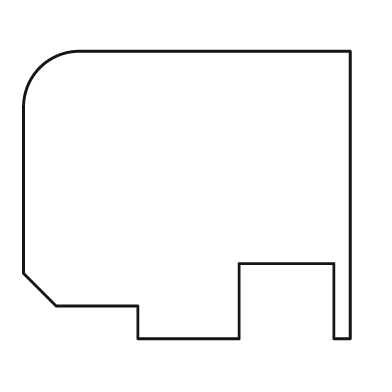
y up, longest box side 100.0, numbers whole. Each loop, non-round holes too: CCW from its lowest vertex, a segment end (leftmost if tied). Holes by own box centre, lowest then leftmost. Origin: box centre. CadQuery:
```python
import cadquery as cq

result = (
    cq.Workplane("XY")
    .moveTo(-15.0, -44.0)
    .lineTo(16.0, -44.0)
    .lineTo(16.0, -21.0)
    .lineTo(45.0, -21.0)
    .lineTo(45.0, -44.0)
    .lineTo(50.0, -44.0)
    .lineTo(50.0, 44.0)
    .lineTo(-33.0, 44.0)
    .threePointArc((-45.0, 39.0), (-50.0, 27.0))
    .lineTo(-50.0, -24.0)
    .lineTo(-40.0, -34.0)
    .lineTo(-15.0, -34.0)
    .close()
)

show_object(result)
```